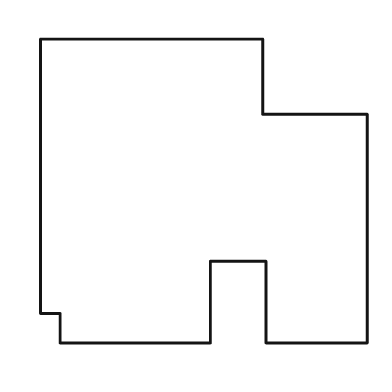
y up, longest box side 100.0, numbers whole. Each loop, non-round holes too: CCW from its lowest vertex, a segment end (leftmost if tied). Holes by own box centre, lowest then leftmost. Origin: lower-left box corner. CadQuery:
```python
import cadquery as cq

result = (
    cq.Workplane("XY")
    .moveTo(6.0, 0.0)
    .lineTo(52.0, 0.0)
    .lineTo(52.0, 25.0)
    .lineTo(69.0, 25.0)
    .lineTo(69.0, 0.0)
    .lineTo(100.0, 0.0)
    .lineTo(100.0, 70.0)
    .lineTo(68.0, 70.0)
    .lineTo(68.0, 93.0)
    .lineTo(0.0, 93.0)
    .lineTo(0.0, 9.0)
    .lineTo(6.0, 9.0)
    .close()
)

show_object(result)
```